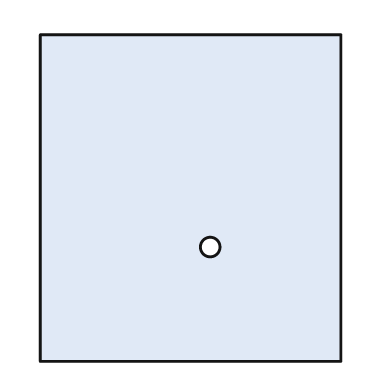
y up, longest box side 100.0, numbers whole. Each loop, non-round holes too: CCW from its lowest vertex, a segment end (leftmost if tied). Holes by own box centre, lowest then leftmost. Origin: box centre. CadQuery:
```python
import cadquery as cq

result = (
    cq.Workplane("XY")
    .moveTo(-46.0, -50.0)
    .lineTo(46.0, -50.0)
    .lineTo(46.0, 50.0)
    .lineTo(-46.0, 50.0)
    .close()
    .moveTo(6.0, -15.0)
    .circle(3.0)
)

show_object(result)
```